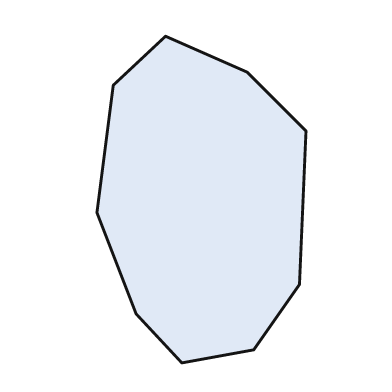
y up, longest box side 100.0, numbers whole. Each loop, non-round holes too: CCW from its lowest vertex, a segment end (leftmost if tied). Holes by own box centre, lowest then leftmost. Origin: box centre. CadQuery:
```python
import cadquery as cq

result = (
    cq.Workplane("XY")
    .moveTo(-6.0, -50.0)
    .lineTo(16.0, -46.0)
    .lineTo(30.0, -26.0)
    .lineTo(32.0, 21.0)
    .lineTo(14.0, 39.0)
    .lineTo(-11.0, 50.0)
    .lineTo(-27.0, 35.0)
    .lineTo(-32.0, -4.0)
    .lineTo(-20.0, -35.0)
    .close()
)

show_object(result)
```